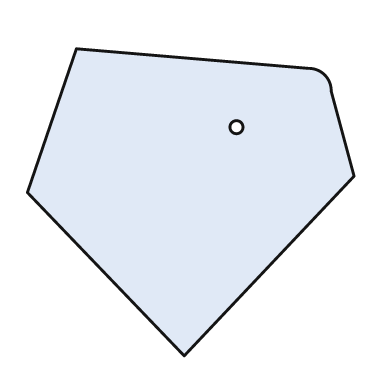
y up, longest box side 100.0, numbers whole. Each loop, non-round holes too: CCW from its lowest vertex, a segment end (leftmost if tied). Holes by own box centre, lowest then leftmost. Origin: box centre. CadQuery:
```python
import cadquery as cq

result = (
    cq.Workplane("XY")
    .moveTo(-2.0, -47.0)
    .lineTo(50.0, 8.0)
    .lineTo(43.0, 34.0)
    .threePointArc((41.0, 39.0), (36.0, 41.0))
    .lineTo(-35.0, 47.0)
    .lineTo(-50.0, 3.0)
    .close()
    .moveTo(14.0, 23.0)
    .circle(2.0)
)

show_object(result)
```